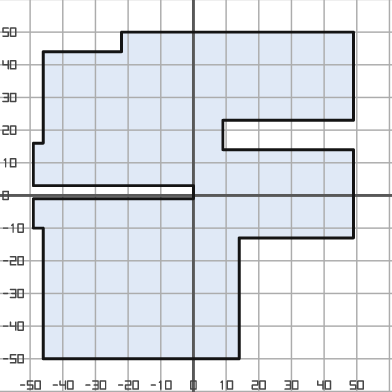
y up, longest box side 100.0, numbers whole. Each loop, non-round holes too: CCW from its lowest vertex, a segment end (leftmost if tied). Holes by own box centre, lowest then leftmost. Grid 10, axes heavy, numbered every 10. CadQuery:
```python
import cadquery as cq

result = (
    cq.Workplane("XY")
    .moveTo(-46.0, -50.0)
    .lineTo(14.0, -50.0)
    .lineTo(14.0, -13.0)
    .lineTo(49.0, -13.0)
    .lineTo(49.0, 14.0)
    .lineTo(9.0, 14.0)
    .lineTo(9.0, 23.0)
    .lineTo(49.0, 23.0)
    .lineTo(49.0, 50.0)
    .lineTo(-22.0, 50.0)
    .lineTo(-22.0, 44.0)
    .lineTo(-46.0, 44.0)
    .lineTo(-46.0, 16.0)
    .lineTo(-49.0, 16.0)
    .lineTo(-49.0, 3.0)
    .lineTo(0.0, 3.0)
    .lineTo(0.0, -1.0)
    .lineTo(-49.0, -1.0)
    .lineTo(-49.0, -10.0)
    .lineTo(-46.0, -10.0)
    .close()
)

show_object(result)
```